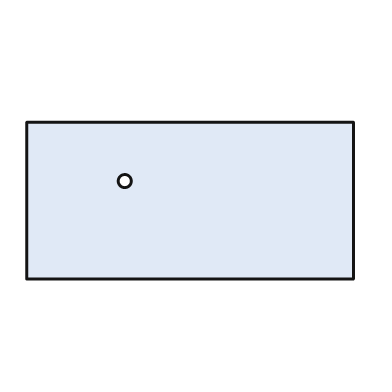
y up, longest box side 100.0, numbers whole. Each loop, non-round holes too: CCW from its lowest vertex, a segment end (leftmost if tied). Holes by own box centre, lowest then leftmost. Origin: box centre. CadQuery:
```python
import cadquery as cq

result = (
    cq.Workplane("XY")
    .moveTo(-50.0, -24.0)
    .lineTo(50.0, -24.0)
    .lineTo(50.0, 24.0)
    .lineTo(-50.0, 24.0)
    .close()
    .moveTo(-20.0, 6.0)
    .circle(2.0)
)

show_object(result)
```